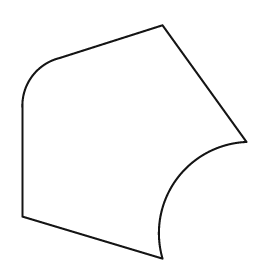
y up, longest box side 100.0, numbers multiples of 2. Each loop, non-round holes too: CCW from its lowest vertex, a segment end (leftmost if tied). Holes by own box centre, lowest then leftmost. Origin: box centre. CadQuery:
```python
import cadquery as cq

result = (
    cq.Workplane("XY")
    .moveTo(12.0, -50.0)
    .threePointArc((18.0, -16.0), (48.0, 0.0))
    .lineTo(12.0, 50.0)
    .lineTo(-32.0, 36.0)
    .threePointArc((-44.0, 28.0), (-48.0, 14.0))
    .lineTo(-48.0, -32.0)
    .close()
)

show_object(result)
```